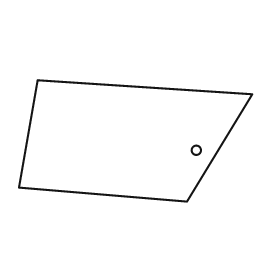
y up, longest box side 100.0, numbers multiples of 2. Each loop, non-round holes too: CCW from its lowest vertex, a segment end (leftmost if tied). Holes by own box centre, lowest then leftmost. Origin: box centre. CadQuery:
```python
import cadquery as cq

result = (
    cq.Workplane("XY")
    .moveTo(22.0, -26.0)
    .lineTo(50.0, 20.0)
    .lineTo(-42.0, 26.0)
    .lineTo(-50.0, -20.0)
    .close()
    .moveTo(26.0, -4.0)
    .circle(2.0)
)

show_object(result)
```